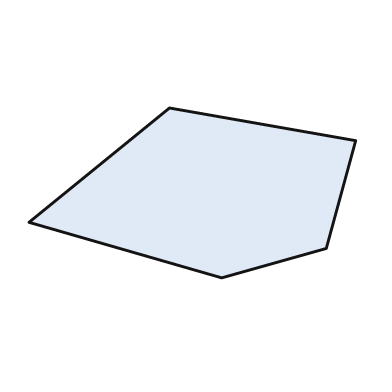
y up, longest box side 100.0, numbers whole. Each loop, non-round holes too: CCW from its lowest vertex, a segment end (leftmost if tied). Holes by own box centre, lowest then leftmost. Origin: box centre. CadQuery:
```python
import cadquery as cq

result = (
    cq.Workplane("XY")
    .moveTo(9.0, -26.0)
    .lineTo(41.0, -17.0)
    .lineTo(50.0, 16.0)
    .lineTo(-7.0, 26.0)
    .lineTo(-50.0, -9.0)
    .close()
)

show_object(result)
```